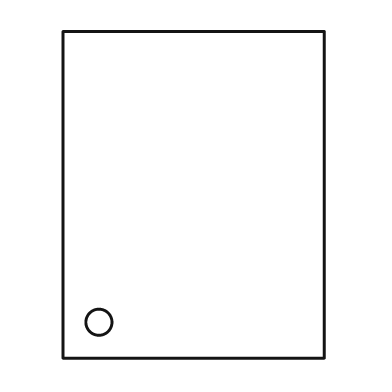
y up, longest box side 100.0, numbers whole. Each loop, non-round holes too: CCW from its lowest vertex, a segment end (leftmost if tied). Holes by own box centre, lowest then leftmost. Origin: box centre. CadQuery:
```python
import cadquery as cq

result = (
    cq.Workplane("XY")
    .moveTo(-40.0, -50.0)
    .lineTo(40.0, -50.0)
    .lineTo(40.0, 50.0)
    .lineTo(-40.0, 50.0)
    .close()
    .moveTo(-29.0, -39.0)
    .circle(4.0)
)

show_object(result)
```